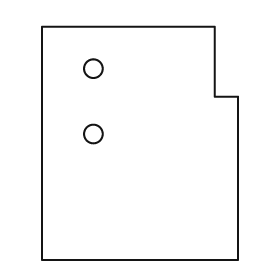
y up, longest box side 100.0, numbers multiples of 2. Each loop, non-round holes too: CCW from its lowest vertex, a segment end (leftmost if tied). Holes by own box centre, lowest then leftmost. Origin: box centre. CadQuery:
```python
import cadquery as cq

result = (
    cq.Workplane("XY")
    .moveTo(-42.0, -50.0)
    .lineTo(42.0, -50.0)
    .lineTo(42.0, 20.0)
    .lineTo(32.0, 20.0)
    .lineTo(32.0, 50.0)
    .lineTo(-42.0, 50.0)
    .close()
    .moveTo(-20.0, 4.0)
    .circle(4.0)
    .moveTo(-20.0, 32.0)
    .circle(4.0)
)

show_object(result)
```